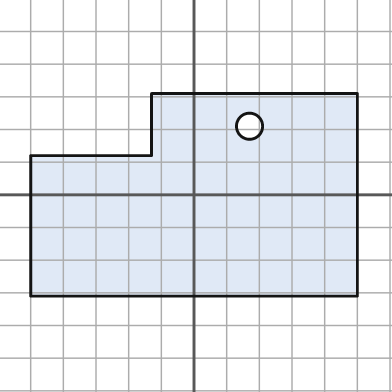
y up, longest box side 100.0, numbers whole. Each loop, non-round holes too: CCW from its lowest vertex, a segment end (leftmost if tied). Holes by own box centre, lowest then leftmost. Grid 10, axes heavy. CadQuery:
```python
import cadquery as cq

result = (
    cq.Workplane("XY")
    .moveTo(-50.0, -31.0)
    .lineTo(50.0, -31.0)
    .lineTo(50.0, 31.0)
    .lineTo(-13.0, 31.0)
    .lineTo(-13.0, 12.0)
    .lineTo(-50.0, 12.0)
    .close()
    .moveTo(17.0, 21.0)
    .circle(4.0)
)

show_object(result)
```